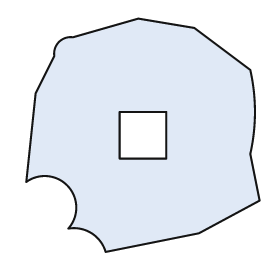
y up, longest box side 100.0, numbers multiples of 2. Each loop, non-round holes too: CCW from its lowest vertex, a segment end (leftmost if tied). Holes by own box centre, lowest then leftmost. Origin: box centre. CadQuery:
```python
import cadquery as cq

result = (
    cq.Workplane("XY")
    .moveTo(-16.0, -50.0)
    .lineTo(24.0, -42.0)
    .lineTo(50.0, -28.0)
    .lineTo(46.0, -8.0)
    .threePointArc((48.0, 10.0), (46.0, 28.0))
    .lineTo(22.0, 46.0)
    .lineTo(-2.0, 50.0)
    .lineTo(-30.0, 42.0)
    .threePointArc((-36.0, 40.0), (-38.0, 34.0))
    .lineTo(-46.0, 18.0)
    .lineTo(-50.0, -20.0)
    .threePointArc((-32.0, -22.0), (-32.0, -40.0))
    .threePointArc((-22.0, -42.0), (-16.0, -50.0))
    .close()
    .moveTo(-10.0, -10.0)
    .lineTo(10.0, -10.0)
    .lineTo(10.0, 10.0)
    .lineTo(-10.0, 10.0)
    .close()
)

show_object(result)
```